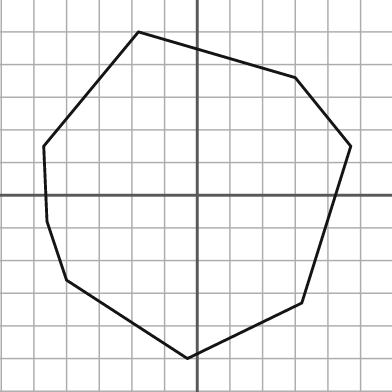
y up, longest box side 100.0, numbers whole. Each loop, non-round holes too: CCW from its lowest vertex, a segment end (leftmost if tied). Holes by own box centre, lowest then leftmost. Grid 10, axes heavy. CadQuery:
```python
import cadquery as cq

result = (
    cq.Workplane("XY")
    .moveTo(-3.0, -50.0)
    .lineTo(32.0, -33.0)
    .lineTo(47.0, 15.0)
    .lineTo(30.0, 36.0)
    .lineTo(-18.0, 50.0)
    .lineTo(-47.0, 15.0)
    .lineTo(-46.0, -8.0)
    .lineTo(-40.0, -26.0)
    .close()
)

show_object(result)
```